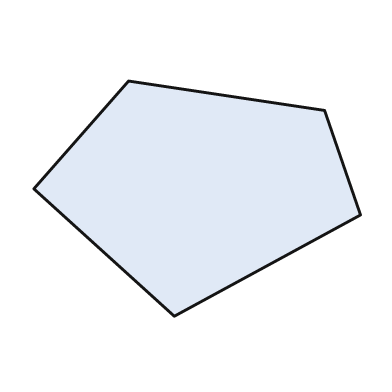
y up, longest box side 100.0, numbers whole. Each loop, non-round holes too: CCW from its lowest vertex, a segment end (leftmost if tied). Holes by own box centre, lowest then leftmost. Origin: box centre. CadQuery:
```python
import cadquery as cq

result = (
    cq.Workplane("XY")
    .moveTo(-7.0, -36.0)
    .lineTo(50.0, -5.0)
    .lineTo(39.0, 27.0)
    .lineTo(-21.0, 36.0)
    .lineTo(-50.0, 3.0)
    .close()
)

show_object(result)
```